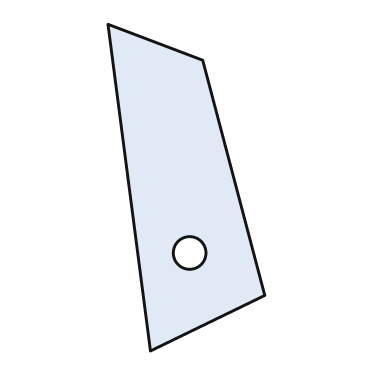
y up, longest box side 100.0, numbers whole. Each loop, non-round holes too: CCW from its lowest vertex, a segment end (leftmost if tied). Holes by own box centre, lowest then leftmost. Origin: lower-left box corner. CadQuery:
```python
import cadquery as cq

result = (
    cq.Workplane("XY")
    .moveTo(13.0, 0.0)
    .lineTo(48.0, 17.0)
    .lineTo(29.0, 89.0)
    .lineTo(0.0, 100.0)
    .close()
    .moveTo(25.0, 30.0)
    .circle(5.0)
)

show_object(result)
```